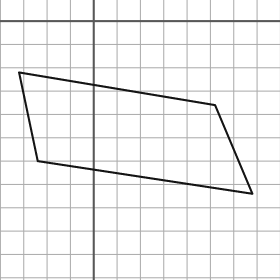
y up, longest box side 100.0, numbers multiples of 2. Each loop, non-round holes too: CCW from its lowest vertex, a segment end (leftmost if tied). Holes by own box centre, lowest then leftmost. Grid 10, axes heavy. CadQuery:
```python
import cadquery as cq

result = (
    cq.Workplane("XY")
    .moveTo(68.0, -74.0)
    .lineTo(52.0, -36.0)
    .lineTo(-32.0, -22.0)
    .lineTo(-24.0, -60.0)
    .close()
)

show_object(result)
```